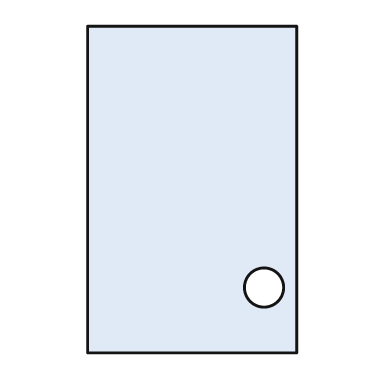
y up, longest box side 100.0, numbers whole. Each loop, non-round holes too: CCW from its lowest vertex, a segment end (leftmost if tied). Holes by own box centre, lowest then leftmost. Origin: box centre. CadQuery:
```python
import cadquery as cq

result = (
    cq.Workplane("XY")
    .moveTo(-32.0, -50.0)
    .lineTo(32.0, -50.0)
    .lineTo(32.0, 50.0)
    .lineTo(-32.0, 50.0)
    .close()
    .moveTo(22.0, -30.0)
    .circle(6.0)
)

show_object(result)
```